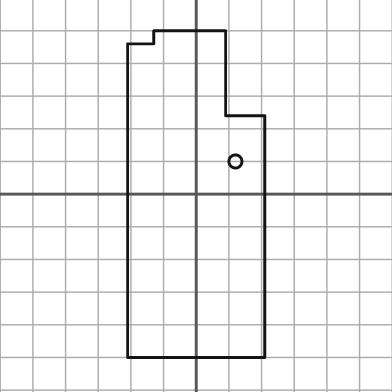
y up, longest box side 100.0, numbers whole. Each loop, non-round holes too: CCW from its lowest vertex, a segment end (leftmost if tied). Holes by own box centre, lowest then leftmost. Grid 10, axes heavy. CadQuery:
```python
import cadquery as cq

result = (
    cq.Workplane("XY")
    .moveTo(-21.0, -50.0)
    .lineTo(21.0, -50.0)
    .lineTo(21.0, 24.0)
    .lineTo(9.0, 24.0)
    .lineTo(9.0, 50.0)
    .lineTo(-13.0, 50.0)
    .lineTo(-13.0, 46.0)
    .lineTo(-21.0, 46.0)
    .close()
    .moveTo(12.0, 10.0)
    .circle(2.0)
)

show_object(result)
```